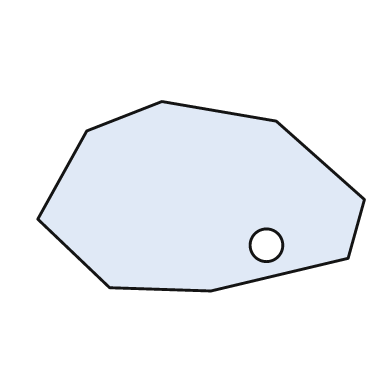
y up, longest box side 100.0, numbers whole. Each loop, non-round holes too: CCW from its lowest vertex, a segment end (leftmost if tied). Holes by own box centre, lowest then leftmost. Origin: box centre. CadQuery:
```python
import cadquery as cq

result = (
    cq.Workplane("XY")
    .moveTo(3.0, -29.0)
    .lineTo(45.0, -19.0)
    .lineTo(50.0, -1.0)
    .lineTo(23.0, 23.0)
    .lineTo(-12.0, 29.0)
    .lineTo(-35.0, 20.0)
    .lineTo(-50.0, -7.0)
    .lineTo(-28.0, -28.0)
    .close()
    .moveTo(20.0, -15.0)
    .circle(5.0)
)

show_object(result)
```